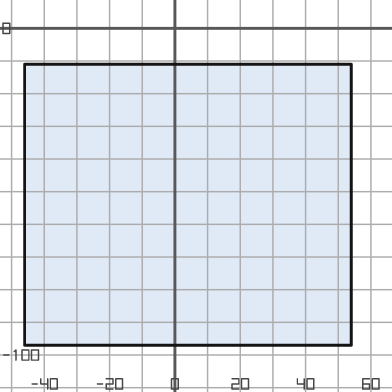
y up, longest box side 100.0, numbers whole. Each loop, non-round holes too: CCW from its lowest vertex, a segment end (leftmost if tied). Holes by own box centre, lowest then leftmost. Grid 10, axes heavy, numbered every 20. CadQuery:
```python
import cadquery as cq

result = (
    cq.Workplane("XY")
    .moveTo(-46.0, -97.0)
    .lineTo(54.0, -97.0)
    .lineTo(54.0, -11.0)
    .lineTo(-46.0, -11.0)
    .close()
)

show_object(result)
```